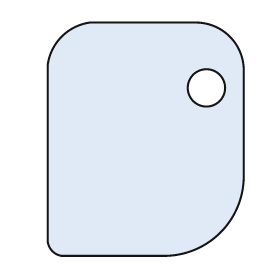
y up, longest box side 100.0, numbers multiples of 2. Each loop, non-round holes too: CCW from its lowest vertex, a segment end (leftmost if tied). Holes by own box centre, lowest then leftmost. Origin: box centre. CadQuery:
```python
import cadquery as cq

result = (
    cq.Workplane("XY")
    .moveTo(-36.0, -50.0)
    .lineTo(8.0, -50.0)
    .threePointArc((32.0, -40.0), (42.0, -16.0))
    .lineTo(42.0, 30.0)
    .threePointArc((36.0, 44.0), (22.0, 50.0))
    .lineTo(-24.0, 50.0)
    .threePointArc((-36.0, 44.0), (-42.0, 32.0))
    .lineTo(-42.0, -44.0)
    .threePointArc((-40.0, -48.0), (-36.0, -50.0))
    .close()
    .moveTo(26.0, 22.0)
    .circle(8.0)
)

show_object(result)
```